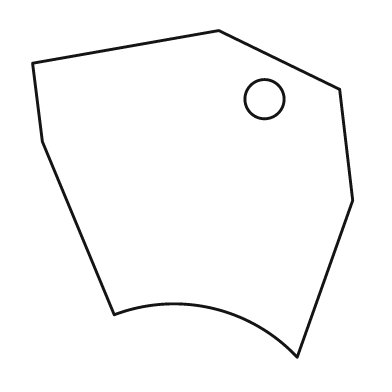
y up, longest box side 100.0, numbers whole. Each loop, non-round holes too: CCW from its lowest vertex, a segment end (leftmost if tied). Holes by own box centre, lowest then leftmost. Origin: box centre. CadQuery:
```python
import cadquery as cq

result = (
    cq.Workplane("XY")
    .moveTo(32.0, -50.0)
    .lineTo(49.0, -2.0)
    .lineTo(45.0, 32.0)
    .lineTo(8.0, 50.0)
    .lineTo(-49.0, 40.0)
    .lineTo(-46.0, 16.0)
    .lineTo(-24.0, -37.0)
    .threePointArc((6.0, -35.0), (32.0, -50.0))
    .close()
    .moveTo(22.0, 29.0)
    .circle(6.0)
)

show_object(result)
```